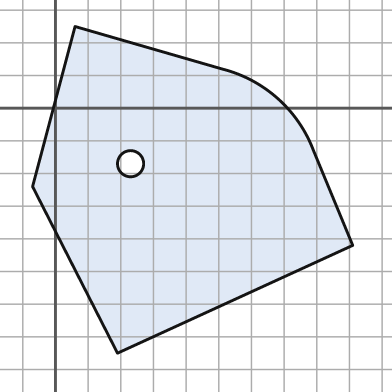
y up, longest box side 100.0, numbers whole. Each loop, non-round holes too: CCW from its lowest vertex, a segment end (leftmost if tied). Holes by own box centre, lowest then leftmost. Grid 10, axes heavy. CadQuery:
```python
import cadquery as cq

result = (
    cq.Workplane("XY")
    .moveTo(19.0, -75.0)
    .lineTo(91.0, -42.0)
    .lineTo(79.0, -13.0)
    .threePointArc((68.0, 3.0), (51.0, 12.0))
    .lineTo(6.0, 25.0)
    .lineTo(-7.0, -24.0)
    .close()
    .moveTo(23.0, -17.0)
    .circle(4.0)
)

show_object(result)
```